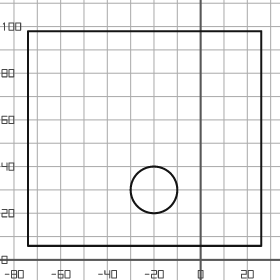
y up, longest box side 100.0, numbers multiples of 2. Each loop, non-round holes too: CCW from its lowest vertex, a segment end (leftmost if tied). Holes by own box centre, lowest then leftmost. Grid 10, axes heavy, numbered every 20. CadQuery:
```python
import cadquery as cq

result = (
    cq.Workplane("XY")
    .moveTo(-74.0, 6.0)
    .lineTo(26.0, 6.0)
    .lineTo(26.0, 98.0)
    .lineTo(-74.0, 98.0)
    .close()
    .moveTo(-20.0, 30.0)
    .circle(10.0)
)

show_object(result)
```